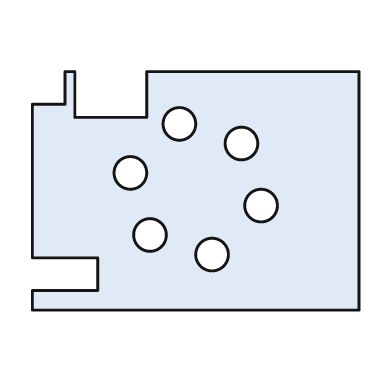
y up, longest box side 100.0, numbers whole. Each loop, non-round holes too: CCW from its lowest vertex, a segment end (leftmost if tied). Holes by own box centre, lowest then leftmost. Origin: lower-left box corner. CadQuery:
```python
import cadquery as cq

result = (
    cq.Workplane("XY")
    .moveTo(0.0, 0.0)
    .lineTo(100.0, 0.0)
    .lineTo(100.0, 73.0)
    .lineTo(35.0, 73.0)
    .lineTo(35.0, 59.0)
    .lineTo(13.0, 59.0)
    .lineTo(13.0, 73.0)
    .lineTo(10.0, 73.0)
    .lineTo(10.0, 63.0)
    .lineTo(0.0, 63.0)
    .lineTo(0.0, 16.0)
    .lineTo(20.0, 16.0)
    .lineTo(20.0, 6.0)
    .lineTo(0.0, 6.0)
    .close()
    .moveTo(55.0, 17.0)
    .circle(5.0)
    .moveTo(36.0, 23.0)
    .circle(5.0)
    .moveTo(70.0, 32.0)
    .circle(5.0)
    .moveTo(30.0, 42.0)
    .circle(5.0)
    .moveTo(64.0, 51.0)
    .circle(5.0)
    .moveTo(45.0, 57.0)
    .circle(5.0)
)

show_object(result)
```